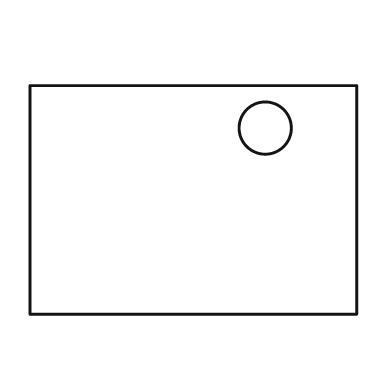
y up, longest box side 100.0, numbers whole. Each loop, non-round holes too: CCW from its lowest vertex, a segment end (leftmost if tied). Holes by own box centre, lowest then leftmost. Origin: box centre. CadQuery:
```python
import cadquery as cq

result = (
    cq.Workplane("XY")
    .moveTo(-50.0, -35.0)
    .lineTo(50.0, -35.0)
    .lineTo(50.0, 35.0)
    .lineTo(-50.0, 35.0)
    .close()
    .moveTo(22.0, 22.0)
    .circle(8.0)
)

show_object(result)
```